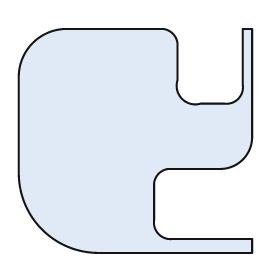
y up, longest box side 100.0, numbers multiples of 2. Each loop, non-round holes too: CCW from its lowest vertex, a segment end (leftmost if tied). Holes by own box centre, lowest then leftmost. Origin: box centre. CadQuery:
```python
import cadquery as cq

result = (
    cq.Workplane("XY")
    .moveTo(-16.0, -48.0)
    .lineTo(50.0, -48.0)
    .lineTo(50.0, -42.0)
    .lineTo(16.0, -42.0)
    .threePointArc((10.0, -40.0), (8.0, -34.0))
    .lineTo(8.0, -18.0)
    .threePointArc((10.0, -14.0), (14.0, -12.0))
    .lineTo(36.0, -12.0)
    .threePointArc((46.0, -8.0), (50.0, 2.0))
    .lineTo(50.0, 48.0)
    .lineTo(46.0, 48.0)
    .lineTo(46.0, 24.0)
    .threePointArc((44.0, 18.0), (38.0, 16.0))
    .lineTo(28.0, 16.0)
    .threePointArc((20.0, 18.0), (18.0, 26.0))
    .lineTo(18.0, 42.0)
    .threePointArc((16.0, 46.0), (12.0, 48.0))
    .lineTo(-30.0, 48.0)
    .threePointArc((-44.0, 42.0), (-50.0, 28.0))
    .lineTo(-50.0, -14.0)
    .threePointArc((-40.0, -38.0), (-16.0, -48.0))
    .close()
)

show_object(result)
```